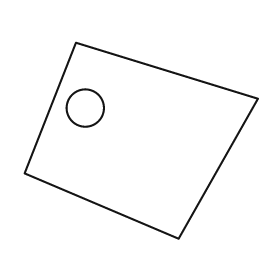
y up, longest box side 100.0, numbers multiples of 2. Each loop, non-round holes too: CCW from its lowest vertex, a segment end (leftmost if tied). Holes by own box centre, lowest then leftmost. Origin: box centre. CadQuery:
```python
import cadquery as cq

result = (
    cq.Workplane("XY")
    .moveTo(16.0, -42.0)
    .lineTo(50.0, 18.0)
    .lineTo(-28.0, 42.0)
    .lineTo(-50.0, -14.0)
    .close()
    .moveTo(-24.0, 14.0)
    .circle(8.0)
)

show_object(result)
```